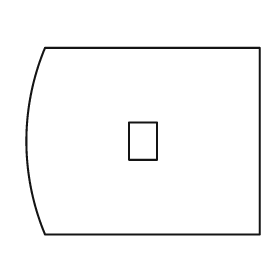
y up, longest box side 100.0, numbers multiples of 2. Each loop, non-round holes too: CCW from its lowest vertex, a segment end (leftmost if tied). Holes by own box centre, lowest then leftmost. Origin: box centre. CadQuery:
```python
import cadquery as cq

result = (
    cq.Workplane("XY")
    .moveTo(-42.0, -40.0)
    .lineTo(50.0, -40.0)
    .lineTo(50.0, 40.0)
    .lineTo(-42.0, 40.0)
    .threePointArc((-50.0, 0.0), (-42.0, -40.0))
    .close()
    .moveTo(-6.0, -8.0)
    .lineTo(6.0, -8.0)
    .lineTo(6.0, 8.0)
    .lineTo(-6.0, 8.0)
    .close()
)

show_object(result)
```